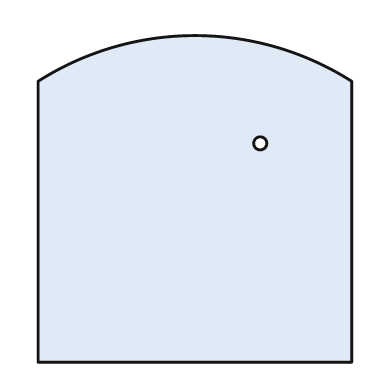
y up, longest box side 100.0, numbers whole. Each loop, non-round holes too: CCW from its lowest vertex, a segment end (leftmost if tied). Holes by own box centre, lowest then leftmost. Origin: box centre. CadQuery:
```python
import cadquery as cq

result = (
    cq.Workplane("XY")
    .moveTo(-48.0, -50.0)
    .lineTo(48.0, -50.0)
    .lineTo(48.0, 36.0)
    .threePointArc((0.0, 50.0), (-48.0, 36.0))
    .close()
    .moveTo(20.0, 17.0)
    .circle(2.0)
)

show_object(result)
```